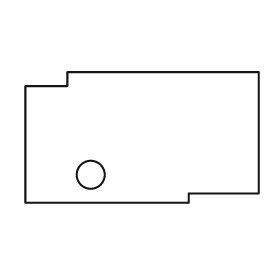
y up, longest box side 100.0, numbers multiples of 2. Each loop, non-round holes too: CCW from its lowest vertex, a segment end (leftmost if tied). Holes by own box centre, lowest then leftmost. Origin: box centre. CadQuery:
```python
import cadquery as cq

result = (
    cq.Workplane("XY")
    .moveTo(-50.0, -28.0)
    .lineTo(20.0, -28.0)
    .lineTo(20.0, -24.0)
    .lineTo(50.0, -24.0)
    .lineTo(50.0, 28.0)
    .lineTo(-32.0, 28.0)
    .lineTo(-32.0, 22.0)
    .lineTo(-50.0, 22.0)
    .close()
    .moveTo(-22.0, -16.0)
    .circle(6.0)
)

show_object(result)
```